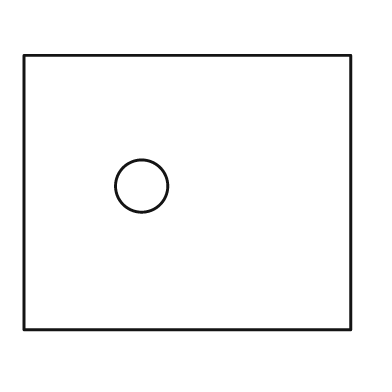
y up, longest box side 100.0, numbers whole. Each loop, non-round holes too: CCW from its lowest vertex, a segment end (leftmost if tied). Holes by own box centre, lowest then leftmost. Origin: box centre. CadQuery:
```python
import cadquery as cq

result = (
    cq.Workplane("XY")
    .moveTo(-50.0, -42.0)
    .lineTo(50.0, -42.0)
    .lineTo(50.0, 42.0)
    .lineTo(-50.0, 42.0)
    .close()
    .moveTo(-14.0, 2.0)
    .circle(8.0)
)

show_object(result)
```